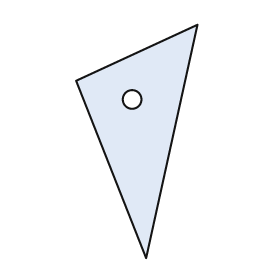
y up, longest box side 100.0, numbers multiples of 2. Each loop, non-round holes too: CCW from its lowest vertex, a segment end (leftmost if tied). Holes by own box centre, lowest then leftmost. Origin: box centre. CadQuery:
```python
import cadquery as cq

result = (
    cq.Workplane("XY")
    .moveTo(4.0, -50.0)
    .lineTo(26.0, 50.0)
    .lineTo(-26.0, 26.0)
    .close()
    .moveTo(-2.0, 18.0)
    .circle(4.0)
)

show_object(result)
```